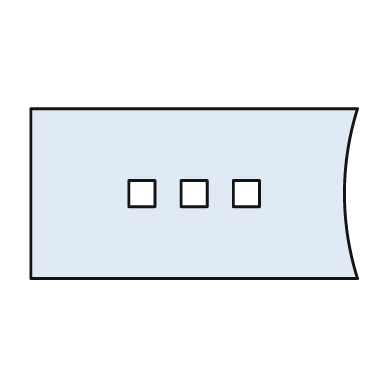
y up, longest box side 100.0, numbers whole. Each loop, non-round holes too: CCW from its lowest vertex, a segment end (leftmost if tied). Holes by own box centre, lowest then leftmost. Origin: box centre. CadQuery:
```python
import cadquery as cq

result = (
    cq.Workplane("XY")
    .moveTo(-50.0, -26.0)
    .lineTo(50.0, -26.0)
    .threePointArc((46.0, 0.0), (50.0, 26.0))
    .lineTo(-50.0, 26.0)
    .close()
    .moveTo(-20.0, -4.0)
    .lineTo(-12.0, -4.0)
    .lineTo(-12.0, 4.0)
    .lineTo(-20.0, 4.0)
    .close()
    .moveTo(-4.0, -4.0)
    .lineTo(4.0, -4.0)
    .lineTo(4.0, 4.0)
    .lineTo(-4.0, 4.0)
    .close()
    .moveTo(12.0, -4.0)
    .lineTo(20.0, -4.0)
    .lineTo(20.0, 4.0)
    .lineTo(12.0, 4.0)
    .close()
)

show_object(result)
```